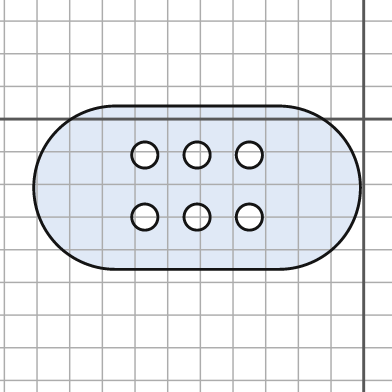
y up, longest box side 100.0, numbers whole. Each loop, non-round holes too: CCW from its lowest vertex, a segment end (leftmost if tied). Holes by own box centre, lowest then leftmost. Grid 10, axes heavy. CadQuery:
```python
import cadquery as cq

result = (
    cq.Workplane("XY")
    .moveTo(-76.0, -46.0)
    .lineTo(-26.0, -46.0)
    .threePointArc((-1.0, -21.0), (-26.0, 4.0))
    .lineTo(-76.0, 4.0)
    .threePointArc((-101.0, -21.0), (-76.0, -46.0))
    .close()
    .moveTo(-67.0, -30.0)
    .circle(4.0)
    .moveTo(-51.0, -30.0)
    .circle(4.0)
    .moveTo(-35.0, -30.0)
    .circle(4.0)
    .moveTo(-67.0, -11.0)
    .circle(4.0)
    .moveTo(-51.0, -11.0)
    .circle(4.0)
    .moveTo(-35.0, -11.0)
    .circle(4.0)
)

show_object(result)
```